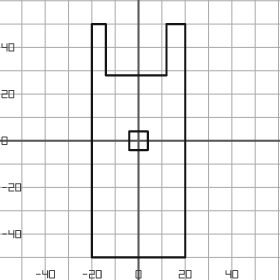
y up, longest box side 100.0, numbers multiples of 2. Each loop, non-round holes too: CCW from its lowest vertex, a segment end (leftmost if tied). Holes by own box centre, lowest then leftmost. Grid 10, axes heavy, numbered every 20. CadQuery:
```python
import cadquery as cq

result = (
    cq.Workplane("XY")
    .moveTo(-20.0, -50.0)
    .lineTo(20.0, -50.0)
    .lineTo(20.0, 50.0)
    .lineTo(12.0, 50.0)
    .lineTo(12.0, 28.0)
    .lineTo(-14.0, 28.0)
    .lineTo(-14.0, 50.0)
    .lineTo(-20.0, 50.0)
    .close()
    .moveTo(-4.0, -4.0)
    .lineTo(4.0, -4.0)
    .lineTo(4.0, 4.0)
    .lineTo(-4.0, 4.0)
    .close()
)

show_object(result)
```